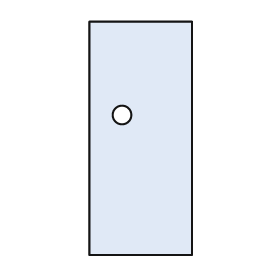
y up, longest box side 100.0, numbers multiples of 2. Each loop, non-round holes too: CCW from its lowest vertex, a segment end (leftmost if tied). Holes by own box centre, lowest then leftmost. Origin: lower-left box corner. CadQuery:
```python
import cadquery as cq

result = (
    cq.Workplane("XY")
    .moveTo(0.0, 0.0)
    .lineTo(44.0, 0.0)
    .lineTo(44.0, 100.0)
    .lineTo(0.0, 100.0)
    .close()
    .moveTo(14.0, 60.0)
    .circle(4.0)
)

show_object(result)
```